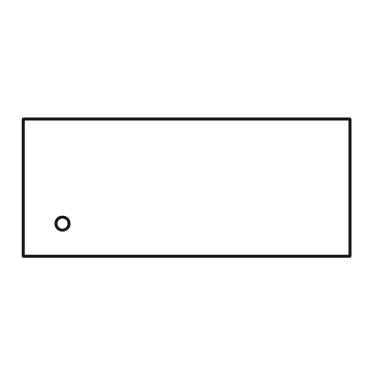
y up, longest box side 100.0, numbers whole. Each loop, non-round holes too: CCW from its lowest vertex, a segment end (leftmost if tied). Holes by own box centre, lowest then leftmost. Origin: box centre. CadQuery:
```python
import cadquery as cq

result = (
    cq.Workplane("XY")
    .moveTo(-50.0, -21.0)
    .lineTo(50.0, -21.0)
    .lineTo(50.0, 21.0)
    .lineTo(-50.0, 21.0)
    .close()
    .moveTo(-38.0, -11.0)
    .circle(2.0)
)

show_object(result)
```